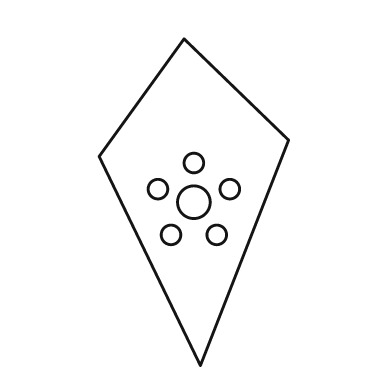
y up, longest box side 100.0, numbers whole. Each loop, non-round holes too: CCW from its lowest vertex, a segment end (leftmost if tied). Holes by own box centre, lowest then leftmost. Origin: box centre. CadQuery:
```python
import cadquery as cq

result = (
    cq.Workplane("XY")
    .moveTo(2.0, -50.0)
    .lineTo(29.0, 19.0)
    .lineTo(-3.0, 50.0)
    .lineTo(-29.0, 14.0)
    .close()
    .moveTo(-7.0, -10.0)
    .circle(3.0)
    .moveTo(7.0, -10.0)
    .circle(3.0)
    .moveTo(0.0, 0.0)
    .circle(5.0)
    .moveTo(-11.0, 4.0)
    .circle(3.0)
    .moveTo(11.0, 4.0)
    .circle(3.0)
    .moveTo(0.0, 12.0)
    .circle(3.0)
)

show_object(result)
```